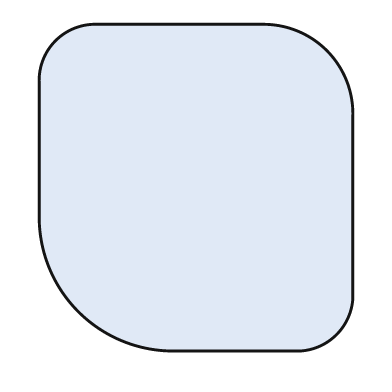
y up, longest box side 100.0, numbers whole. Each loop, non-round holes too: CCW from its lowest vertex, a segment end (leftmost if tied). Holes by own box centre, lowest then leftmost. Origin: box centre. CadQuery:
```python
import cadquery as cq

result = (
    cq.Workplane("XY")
    .moveTo(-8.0, -50.0)
    .lineTo(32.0, -50.0)
    .threePointArc((43.0, -45.0), (48.0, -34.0))
    .lineTo(48.0, 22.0)
    .threePointArc((40.0, 42.0), (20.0, 50.0))
    .lineTo(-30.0, 50.0)
    .threePointArc((-43.0, 45.0), (-48.0, 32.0))
    .lineTo(-48.0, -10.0)
    .threePointArc((-36.0, -38.0), (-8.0, -50.0))
    .close()
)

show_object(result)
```